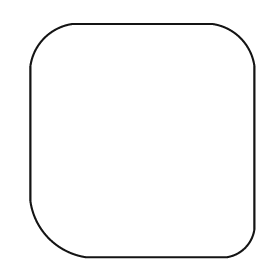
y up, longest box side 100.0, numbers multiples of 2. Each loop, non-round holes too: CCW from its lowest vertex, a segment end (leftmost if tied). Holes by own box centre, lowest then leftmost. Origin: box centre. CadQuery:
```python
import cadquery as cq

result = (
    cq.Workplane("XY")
    .moveTo(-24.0, -50.0)
    .lineTo(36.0, -50.0)
    .threePointArc((44.0, -46.0), (48.0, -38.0))
    .lineTo(48.0, 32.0)
    .threePointArc((42.0, 44.0), (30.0, 50.0))
    .lineTo(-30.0, 50.0)
    .threePointArc((-42.0, 44.0), (-48.0, 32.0))
    .lineTo(-48.0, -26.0)
    .threePointArc((-40.0, -42.0), (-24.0, -50.0))
    .close()
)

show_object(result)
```